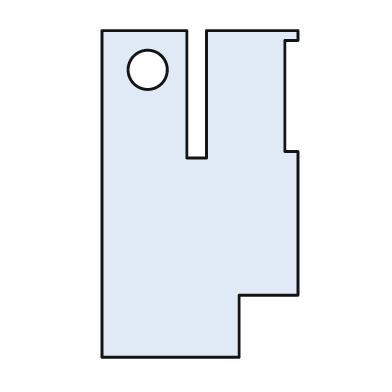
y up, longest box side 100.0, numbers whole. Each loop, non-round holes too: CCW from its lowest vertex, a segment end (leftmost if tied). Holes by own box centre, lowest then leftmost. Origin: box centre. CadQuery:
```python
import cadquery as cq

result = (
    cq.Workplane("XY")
    .moveTo(-30.0, -50.0)
    .lineTo(12.0, -50.0)
    .lineTo(12.0, -31.0)
    .lineTo(30.0, -31.0)
    .lineTo(30.0, 13.0)
    .lineTo(26.0, 13.0)
    .lineTo(26.0, 47.0)
    .lineTo(30.0, 47.0)
    .lineTo(30.0, 50.0)
    .lineTo(2.0, 50.0)
    .lineTo(2.0, 11.0)
    .lineTo(-4.0, 11.0)
    .lineTo(-4.0, 50.0)
    .lineTo(-30.0, 50.0)
    .close()
    .moveTo(-16.0, 38.0)
    .circle(6.0)
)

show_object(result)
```